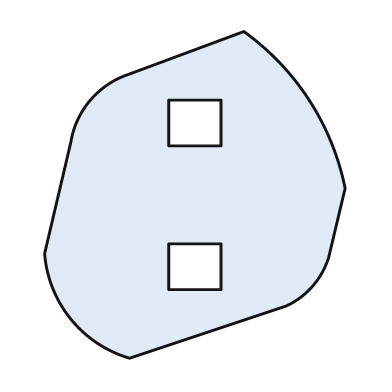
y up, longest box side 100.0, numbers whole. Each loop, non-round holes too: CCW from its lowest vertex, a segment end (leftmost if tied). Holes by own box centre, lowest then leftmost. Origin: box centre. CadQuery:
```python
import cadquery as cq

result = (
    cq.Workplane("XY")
    .moveTo(-20.0, -50.0)
    .lineTo(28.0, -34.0)
    .threePointArc((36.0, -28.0), (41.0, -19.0))
    .lineTo(46.0, 2.0)
    .threePointArc((35.0, 29.0), (15.0, 50.0))
    .lineTo(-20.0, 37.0)
    .threePointArc((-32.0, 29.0), (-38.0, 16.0))
    .lineTo(-46.0, -18.0)
    .threePointArc((-38.0, -38.0), (-20.0, -50.0))
    .close()
    .moveTo(-8.0, -29.0)
    .lineTo(8.0, -29.0)
    .lineTo(8.0, -15.0)
    .lineTo(-8.0, -15.0)
    .close()
    .moveTo(-8.0, 15.0)
    .lineTo(8.0, 15.0)
    .lineTo(8.0, 29.0)
    .lineTo(-8.0, 29.0)
    .close()
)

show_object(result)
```